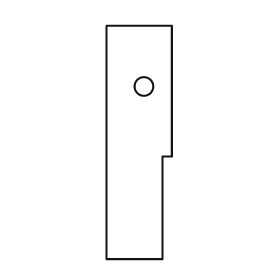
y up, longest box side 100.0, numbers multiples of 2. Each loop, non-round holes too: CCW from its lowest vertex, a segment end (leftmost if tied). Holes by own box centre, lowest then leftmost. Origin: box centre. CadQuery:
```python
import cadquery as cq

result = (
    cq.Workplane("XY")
    .moveTo(-14.0, -50.0)
    .lineTo(10.0, -50.0)
    .lineTo(10.0, -6.0)
    .lineTo(14.0, -6.0)
    .lineTo(14.0, 50.0)
    .lineTo(-14.0, 50.0)
    .close()
    .moveTo(2.0, 24.0)
    .circle(4.0)
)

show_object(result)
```